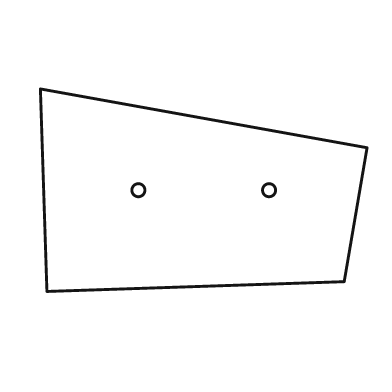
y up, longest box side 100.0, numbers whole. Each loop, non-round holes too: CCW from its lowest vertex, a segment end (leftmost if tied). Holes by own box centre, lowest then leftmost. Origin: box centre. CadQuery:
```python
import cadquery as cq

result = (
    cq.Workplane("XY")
    .moveTo(-48.0, -31.0)
    .lineTo(43.0, -28.0)
    .lineTo(50.0, 13.0)
    .lineTo(-50.0, 31.0)
    .close()
    .moveTo(-20.0, 0.0)
    .circle(2.0)
    .moveTo(20.0, 0.0)
    .circle(2.0)
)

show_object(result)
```